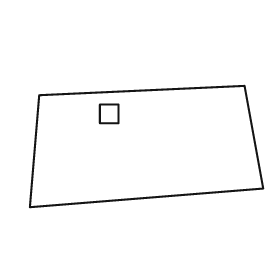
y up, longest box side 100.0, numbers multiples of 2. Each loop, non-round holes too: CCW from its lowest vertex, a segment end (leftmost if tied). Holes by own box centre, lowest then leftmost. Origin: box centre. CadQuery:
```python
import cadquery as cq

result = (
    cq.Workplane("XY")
    .moveTo(-50.0, -26.0)
    .lineTo(50.0, -18.0)
    .lineTo(42.0, 26.0)
    .lineTo(-46.0, 22.0)
    .close()
    .moveTo(-20.0, 10.0)
    .lineTo(-12.0, 10.0)
    .lineTo(-12.0, 18.0)
    .lineTo(-20.0, 18.0)
    .close()
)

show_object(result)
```